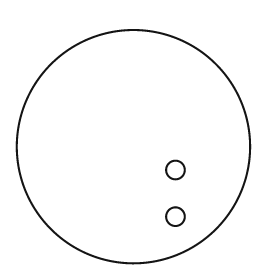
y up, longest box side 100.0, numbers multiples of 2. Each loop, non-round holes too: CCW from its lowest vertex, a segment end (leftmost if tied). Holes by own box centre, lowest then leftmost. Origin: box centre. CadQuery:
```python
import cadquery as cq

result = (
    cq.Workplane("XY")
    .moveTo(0.0, 0.0)
    .circle(50.0)
    .moveTo(18.0, -30.0)
    .circle(4.0)
    .moveTo(18.0, -10.0)
    .circle(4.0)
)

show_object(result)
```